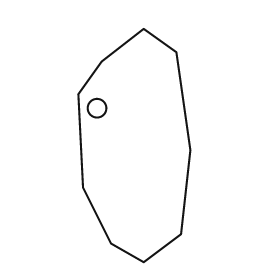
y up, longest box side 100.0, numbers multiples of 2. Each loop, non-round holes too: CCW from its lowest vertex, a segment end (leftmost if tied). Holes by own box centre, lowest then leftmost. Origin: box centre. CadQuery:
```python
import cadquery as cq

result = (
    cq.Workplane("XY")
    .moveTo(4.0, -50.0)
    .lineTo(20.0, -38.0)
    .lineTo(24.0, -2.0)
    .lineTo(18.0, 40.0)
    .lineTo(4.0, 50.0)
    .lineTo(-14.0, 36.0)
    .lineTo(-24.0, 22.0)
    .lineTo(-22.0, -18.0)
    .lineTo(-10.0, -42.0)
    .close()
    .moveTo(-16.0, 16.0)
    .circle(4.0)
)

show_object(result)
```